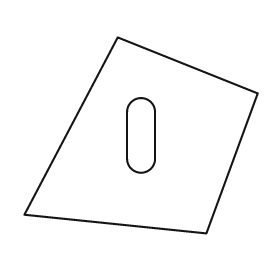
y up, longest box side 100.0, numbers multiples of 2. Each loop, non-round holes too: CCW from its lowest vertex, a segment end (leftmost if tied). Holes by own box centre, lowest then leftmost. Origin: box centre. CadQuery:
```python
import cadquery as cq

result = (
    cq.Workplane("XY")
    .moveTo(28.0, -42.0)
    .lineTo(50.0, 18.0)
    .lineTo(-10.0, 42.0)
    .lineTo(-50.0, -34.0)
    .close()
    .moveTo(-6.0, -10.0)
    .threePointArc((0.0, -16.0), (6.0, -10.0))
    .lineTo(6.0, 10.0)
    .threePointArc((0.0, 16.0), (-6.0, 10.0))
    .close()
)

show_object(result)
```